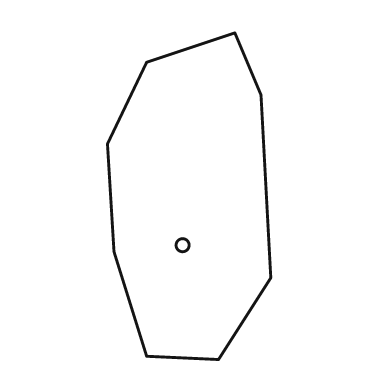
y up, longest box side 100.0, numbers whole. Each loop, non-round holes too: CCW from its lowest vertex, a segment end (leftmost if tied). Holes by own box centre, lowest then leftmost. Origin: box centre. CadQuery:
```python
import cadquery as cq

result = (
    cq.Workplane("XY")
    .moveTo(9.0, -50.0)
    .lineTo(25.0, -25.0)
    .lineTo(22.0, 31.0)
    .lineTo(14.0, 50.0)
    .lineTo(-13.0, 41.0)
    .lineTo(-25.0, 16.0)
    .lineTo(-23.0, -17.0)
    .lineTo(-13.0, -49.0)
    .close()
    .moveTo(-2.0, -15.0)
    .circle(2.0)
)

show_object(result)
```